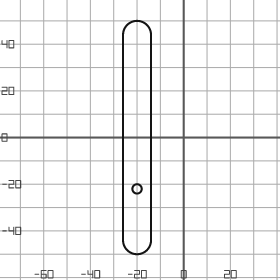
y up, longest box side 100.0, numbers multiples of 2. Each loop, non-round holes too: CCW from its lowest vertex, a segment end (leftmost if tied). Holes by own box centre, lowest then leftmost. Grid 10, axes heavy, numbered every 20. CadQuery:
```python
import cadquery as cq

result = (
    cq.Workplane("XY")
    .moveTo(-26.0, -44.0)
    .threePointArc((-20.0, -50.0), (-14.0, -44.0))
    .lineTo(-14.0, 44.0)
    .threePointArc((-20.0, 50.0), (-26.0, 44.0))
    .close()
    .moveTo(-20.0, -22.0)
    .circle(2.0)
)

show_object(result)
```